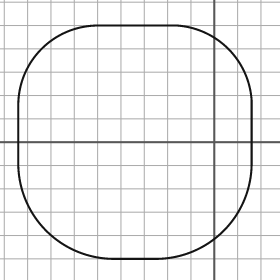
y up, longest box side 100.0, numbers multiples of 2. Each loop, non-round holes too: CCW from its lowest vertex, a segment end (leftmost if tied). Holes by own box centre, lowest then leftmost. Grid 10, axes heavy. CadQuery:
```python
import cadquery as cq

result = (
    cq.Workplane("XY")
    .moveTo(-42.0, -50.0)
    .lineTo(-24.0, -50.0)
    .threePointArc((4.0, -38.0), (16.0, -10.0))
    .lineTo(16.0, 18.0)
    .threePointArc((6.0, 40.0), (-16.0, 50.0))
    .lineTo(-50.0, 50.0)
    .threePointArc((-74.0, 40.0), (-84.0, 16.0))
    .lineTo(-84.0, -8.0)
    .threePointArc((-72.0, -38.0), (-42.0, -50.0))
    .close()
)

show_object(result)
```